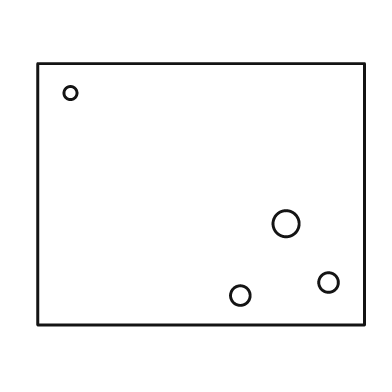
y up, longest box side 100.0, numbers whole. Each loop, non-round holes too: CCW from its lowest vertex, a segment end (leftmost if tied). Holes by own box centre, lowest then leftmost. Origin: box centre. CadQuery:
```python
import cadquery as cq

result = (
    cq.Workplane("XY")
    .moveTo(-50.0, -40.0)
    .lineTo(50.0, -40.0)
    .lineTo(50.0, 40.0)
    .lineTo(-50.0, 40.0)
    .close()
    .moveTo(12.0, -31.0)
    .circle(3.0)
    .moveTo(39.0, -27.0)
    .circle(3.0)
    .moveTo(26.0, -9.0)
    .circle(4.0)
    .moveTo(-40.0, 31.0)
    .circle(2.0)
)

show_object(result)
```